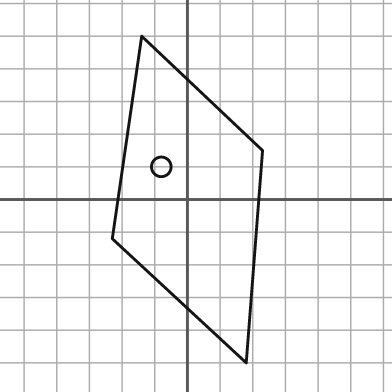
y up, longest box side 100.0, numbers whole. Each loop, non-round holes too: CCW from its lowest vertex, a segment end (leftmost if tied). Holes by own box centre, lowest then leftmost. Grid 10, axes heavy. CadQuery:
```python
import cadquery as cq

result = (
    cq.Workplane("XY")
    .moveTo(18.0, -50.0)
    .lineTo(23.0, 15.0)
    .lineTo(-14.0, 50.0)
    .lineTo(-23.0, -12.0)
    .close()
    .moveTo(-8.0, 10.0)
    .circle(3.0)
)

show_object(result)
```